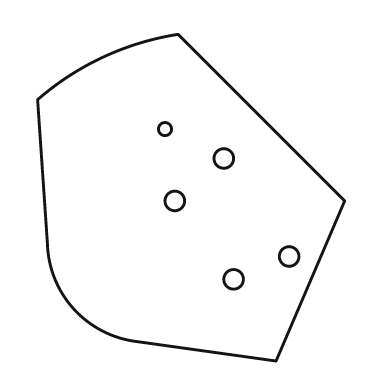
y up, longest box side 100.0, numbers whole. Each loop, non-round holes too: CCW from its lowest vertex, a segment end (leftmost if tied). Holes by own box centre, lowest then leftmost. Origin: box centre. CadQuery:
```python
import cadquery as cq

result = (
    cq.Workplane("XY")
    .moveTo(26.0, -50.0)
    .lineTo(47.0, -1.0)
    .lineTo(-4.0, 50.0)
    .threePointArc((-27.0, 43.0), (-47.0, 30.0))
    .lineTo(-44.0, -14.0)
    .threePointArc((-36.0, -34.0), (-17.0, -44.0))
    .close()
    .moveTo(13.0, -25.0)
    .circle(3.0)
    .moveTo(30.0, -18.0)
    .circle(3.0)
    .moveTo(-5.0, -1.0)
    .circle(3.0)
    .moveTo(10.0, 12.0)
    .circle(3.0)
    .moveTo(-8.0, 21.0)
    .circle(2.0)
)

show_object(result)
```